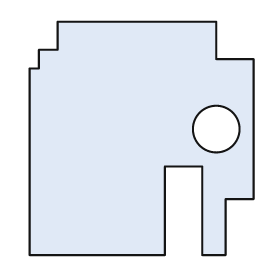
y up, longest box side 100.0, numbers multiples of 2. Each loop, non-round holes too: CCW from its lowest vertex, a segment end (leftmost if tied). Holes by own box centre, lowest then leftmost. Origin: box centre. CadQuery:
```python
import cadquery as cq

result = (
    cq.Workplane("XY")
    .moveTo(-48.0, -50.0)
    .lineTo(10.0, -50.0)
    .lineTo(10.0, -12.0)
    .lineTo(26.0, -12.0)
    .lineTo(26.0, -50.0)
    .lineTo(36.0, -50.0)
    .lineTo(36.0, -26.0)
    .lineTo(48.0, -26.0)
    .lineTo(48.0, 34.0)
    .lineTo(32.0, 34.0)
    .lineTo(32.0, 50.0)
    .lineTo(-36.0, 50.0)
    .lineTo(-36.0, 38.0)
    .lineTo(-44.0, 38.0)
    .lineTo(-44.0, 30.0)
    .lineTo(-48.0, 30.0)
    .close()
    .moveTo(32.0, 4.0)
    .circle(10.0)
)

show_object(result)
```